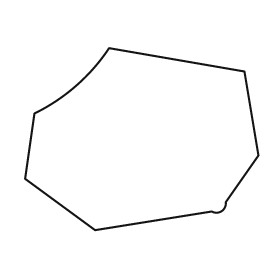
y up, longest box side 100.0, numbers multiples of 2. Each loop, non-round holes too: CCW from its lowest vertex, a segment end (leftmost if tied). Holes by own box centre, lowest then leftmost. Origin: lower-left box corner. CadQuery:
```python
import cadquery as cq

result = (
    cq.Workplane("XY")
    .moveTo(30.0, 0.0)
    .lineTo(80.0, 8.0)
    .threePointArc((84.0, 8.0), (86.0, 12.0))
    .lineTo(100.0, 32.0)
    .lineTo(94.0, 68.0)
    .lineTo(36.0, 78.0)
    .threePointArc((22.0, 62.0), (4.0, 50.0))
    .lineTo(0.0, 22.0)
    .close()
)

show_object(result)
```